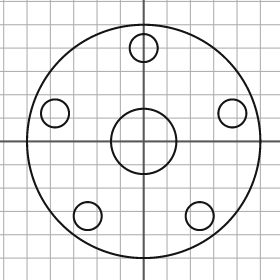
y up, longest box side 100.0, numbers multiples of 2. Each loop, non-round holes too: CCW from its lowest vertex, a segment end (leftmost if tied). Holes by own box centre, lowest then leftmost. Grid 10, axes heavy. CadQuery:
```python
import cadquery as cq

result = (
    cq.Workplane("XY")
    .moveTo(0.0, 0.0)
    .circle(50.0)
    .moveTo(-24.0, -32.0)
    .circle(6.0)
    .moveTo(24.0, -32.0)
    .circle(6.0)
    .moveTo(0.0, 0.0)
    .circle(14.0)
    .moveTo(-38.0, 12.0)
    .circle(6.0)
    .moveTo(38.0, 12.0)
    .circle(6.0)
    .moveTo(0.0, 40.0)
    .circle(6.0)
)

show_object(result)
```